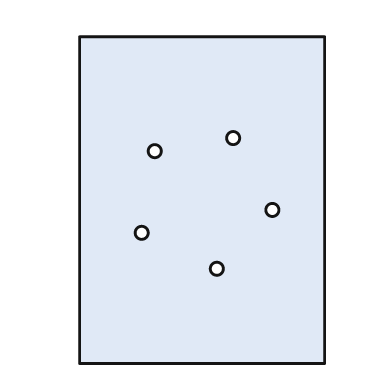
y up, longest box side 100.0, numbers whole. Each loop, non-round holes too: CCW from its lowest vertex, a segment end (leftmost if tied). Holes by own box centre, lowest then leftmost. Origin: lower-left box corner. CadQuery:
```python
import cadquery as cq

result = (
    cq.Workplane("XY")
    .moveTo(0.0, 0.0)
    .lineTo(75.0, 0.0)
    .lineTo(75.0, 100.0)
    .lineTo(0.0, 100.0)
    .close()
    .moveTo(42.0, 29.0)
    .circle(2.0)
    .moveTo(19.0, 40.0)
    .circle(2.0)
    .moveTo(59.0, 47.0)
    .circle(2.0)
    .moveTo(23.0, 65.0)
    .circle(2.0)
    .moveTo(47.0, 69.0)
    .circle(2.0)
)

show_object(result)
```